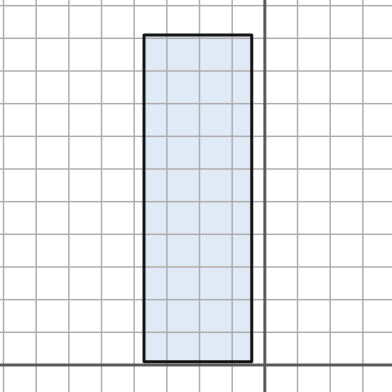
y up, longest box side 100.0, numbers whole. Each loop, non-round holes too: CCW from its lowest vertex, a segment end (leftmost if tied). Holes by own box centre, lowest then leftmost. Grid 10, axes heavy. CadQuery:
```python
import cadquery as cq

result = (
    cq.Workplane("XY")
    .moveTo(-37.0, 1.0)
    .lineTo(-4.0, 1.0)
    .lineTo(-4.0, 101.0)
    .lineTo(-37.0, 101.0)
    .close()
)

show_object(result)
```